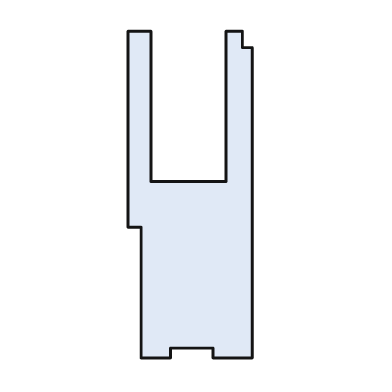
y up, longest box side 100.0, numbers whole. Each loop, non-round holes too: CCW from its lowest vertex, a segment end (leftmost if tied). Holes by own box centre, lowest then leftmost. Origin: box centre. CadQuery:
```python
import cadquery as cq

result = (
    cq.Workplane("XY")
    .moveTo(-15.0, -50.0)
    .lineTo(-6.0, -50.0)
    .lineTo(-6.0, -47.0)
    .lineTo(7.0, -47.0)
    .lineTo(7.0, -50.0)
    .lineTo(19.0, -50.0)
    .lineTo(19.0, 45.0)
    .lineTo(16.0, 45.0)
    .lineTo(16.0, 50.0)
    .lineTo(11.0, 50.0)
    .lineTo(11.0, 4.0)
    .lineTo(-12.0, 4.0)
    .lineTo(-12.0, 50.0)
    .lineTo(-19.0, 50.0)
    .lineTo(-19.0, -10.0)
    .lineTo(-15.0, -10.0)
    .close()
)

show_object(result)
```